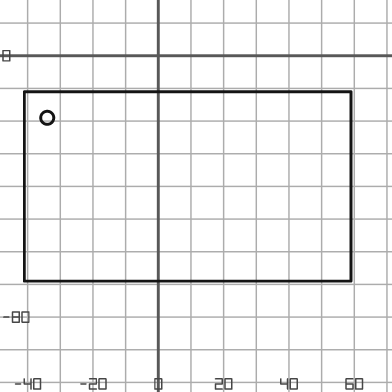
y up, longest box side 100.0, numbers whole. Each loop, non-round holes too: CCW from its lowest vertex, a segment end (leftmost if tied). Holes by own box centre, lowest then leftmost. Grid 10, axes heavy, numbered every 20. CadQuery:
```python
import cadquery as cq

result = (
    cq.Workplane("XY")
    .moveTo(-41.0, -69.0)
    .lineTo(59.0, -69.0)
    .lineTo(59.0, -11.0)
    .lineTo(-41.0, -11.0)
    .close()
    .moveTo(-34.0, -19.0)
    .circle(2.0)
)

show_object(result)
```